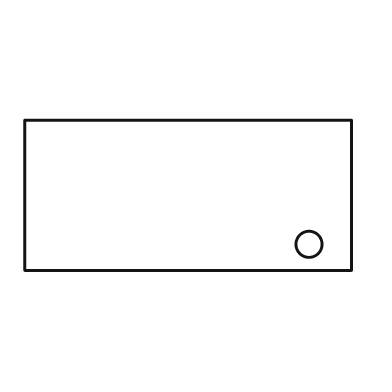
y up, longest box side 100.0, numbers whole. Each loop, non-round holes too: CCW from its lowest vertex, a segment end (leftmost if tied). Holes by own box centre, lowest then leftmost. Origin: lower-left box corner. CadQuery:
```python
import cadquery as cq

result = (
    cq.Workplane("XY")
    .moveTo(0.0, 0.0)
    .lineTo(100.0, 0.0)
    .lineTo(100.0, 46.0)
    .lineTo(0.0, 46.0)
    .close()
    .moveTo(87.0, 8.0)
    .circle(4.0)
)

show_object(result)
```